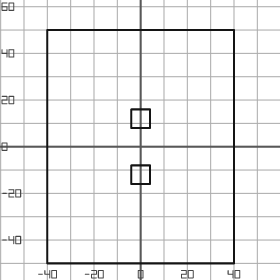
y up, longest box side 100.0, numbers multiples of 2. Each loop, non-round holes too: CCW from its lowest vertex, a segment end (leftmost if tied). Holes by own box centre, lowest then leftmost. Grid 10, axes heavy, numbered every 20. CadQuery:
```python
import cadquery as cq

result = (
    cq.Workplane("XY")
    .moveTo(-40.0, -50.0)
    .lineTo(40.0, -50.0)
    .lineTo(40.0, 50.0)
    .lineTo(-40.0, 50.0)
    .close()
    .moveTo(-4.0, -16.0)
    .lineTo(4.0, -16.0)
    .lineTo(4.0, -8.0)
    .lineTo(-4.0, -8.0)
    .close()
    .moveTo(-4.0, 8.0)
    .lineTo(4.0, 8.0)
    .lineTo(4.0, 16.0)
    .lineTo(-4.0, 16.0)
    .close()
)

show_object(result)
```